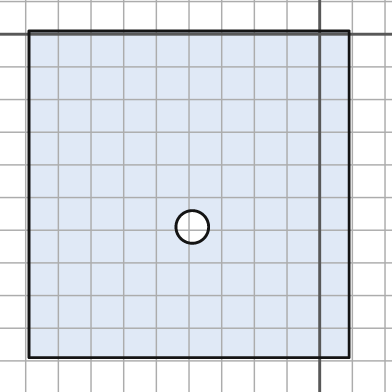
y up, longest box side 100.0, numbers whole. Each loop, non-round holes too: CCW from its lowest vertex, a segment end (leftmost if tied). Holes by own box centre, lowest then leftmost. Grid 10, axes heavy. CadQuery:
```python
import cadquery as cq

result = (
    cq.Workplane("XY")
    .moveTo(-89.0, -99.0)
    .lineTo(9.0, -99.0)
    .lineTo(9.0, 1.0)
    .lineTo(-89.0, 1.0)
    .close()
    .moveTo(-39.0, -59.0)
    .circle(5.0)
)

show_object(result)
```